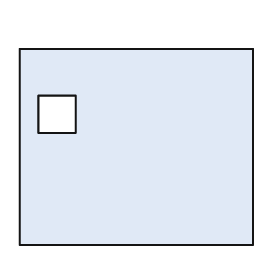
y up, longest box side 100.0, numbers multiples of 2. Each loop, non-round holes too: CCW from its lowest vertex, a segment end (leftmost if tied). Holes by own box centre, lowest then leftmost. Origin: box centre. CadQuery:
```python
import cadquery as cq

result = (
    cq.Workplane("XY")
    .moveTo(-50.0, -42.0)
    .lineTo(50.0, -42.0)
    .lineTo(50.0, 42.0)
    .lineTo(-50.0, 42.0)
    .close()
    .moveTo(-42.0, 6.0)
    .lineTo(-26.0, 6.0)
    .lineTo(-26.0, 22.0)
    .lineTo(-42.0, 22.0)
    .close()
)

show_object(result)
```